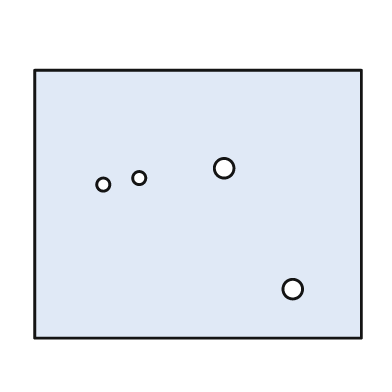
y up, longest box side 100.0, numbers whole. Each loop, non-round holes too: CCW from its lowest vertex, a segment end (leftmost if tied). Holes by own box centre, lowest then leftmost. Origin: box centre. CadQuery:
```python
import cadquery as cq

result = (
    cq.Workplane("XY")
    .moveTo(-50.0, -41.0)
    .lineTo(50.0, -41.0)
    .lineTo(50.0, 41.0)
    .lineTo(-50.0, 41.0)
    .close()
    .moveTo(29.0, -26.0)
    .circle(3.0)
    .moveTo(-29.0, 6.0)
    .circle(2.0)
    .moveTo(-18.0, 8.0)
    .circle(2.0)
    .moveTo(8.0, 11.0)
    .circle(3.0)
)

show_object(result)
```